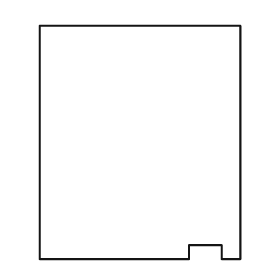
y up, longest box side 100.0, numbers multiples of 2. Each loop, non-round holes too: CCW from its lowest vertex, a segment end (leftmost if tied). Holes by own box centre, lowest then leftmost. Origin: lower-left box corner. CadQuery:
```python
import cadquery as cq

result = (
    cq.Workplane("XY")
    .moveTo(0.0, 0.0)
    .lineTo(64.0, 0.0)
    .lineTo(64.0, 6.0)
    .lineTo(78.0, 6.0)
    .lineTo(78.0, 0.0)
    .lineTo(86.0, 0.0)
    .lineTo(86.0, 100.0)
    .lineTo(0.0, 100.0)
    .close()
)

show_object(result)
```